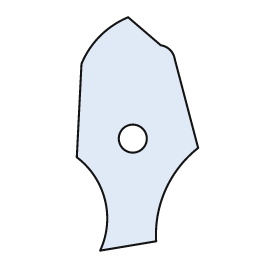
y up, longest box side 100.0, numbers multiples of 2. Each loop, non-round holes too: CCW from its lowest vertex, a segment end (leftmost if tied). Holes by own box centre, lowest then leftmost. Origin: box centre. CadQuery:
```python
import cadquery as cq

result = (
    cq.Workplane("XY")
    .moveTo(-16.0, -50.0)
    .lineTo(8.0, -46.0)
    .threePointArc((12.0, -24.0), (26.0, -6.0))
    .lineTo(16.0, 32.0)
    .threePointArc((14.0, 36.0), (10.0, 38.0))
    .lineTo(-4.0, 50.0)
    .threePointArc((-16.0, 42.0), (-24.0, 30.0))
    .lineTo(-26.0, -10.0)
    .threePointArc((-14.0, -28.0), (-16.0, -50.0))
    .close()
    .moveTo(-2.0, -2.0)
    .circle(6.0)
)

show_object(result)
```